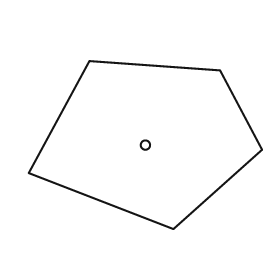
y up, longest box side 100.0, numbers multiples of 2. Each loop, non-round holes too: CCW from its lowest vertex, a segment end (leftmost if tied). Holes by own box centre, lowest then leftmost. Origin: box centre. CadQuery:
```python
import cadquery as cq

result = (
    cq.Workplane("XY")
    .moveTo(12.0, -36.0)
    .lineTo(50.0, -2.0)
    .lineTo(32.0, 32.0)
    .lineTo(-24.0, 36.0)
    .lineTo(-50.0, -12.0)
    .close()
    .moveTo(0.0, 0.0)
    .circle(2.0)
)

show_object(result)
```